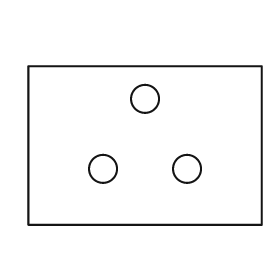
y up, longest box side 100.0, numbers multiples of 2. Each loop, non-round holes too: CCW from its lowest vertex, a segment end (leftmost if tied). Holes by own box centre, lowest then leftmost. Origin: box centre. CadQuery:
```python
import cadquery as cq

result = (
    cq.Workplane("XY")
    .moveTo(-50.0, -34.0)
    .lineTo(50.0, -34.0)
    .lineTo(50.0, 34.0)
    .lineTo(-50.0, 34.0)
    .close()
    .moveTo(-18.0, -10.0)
    .circle(6.0)
    .moveTo(18.0, -10.0)
    .circle(6.0)
    .moveTo(0.0, 20.0)
    .circle(6.0)
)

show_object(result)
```